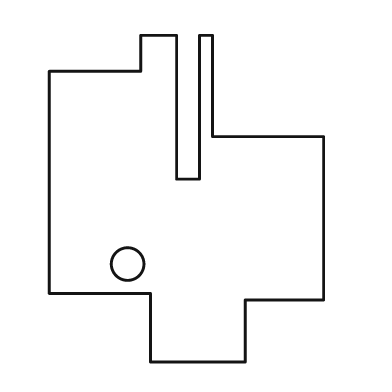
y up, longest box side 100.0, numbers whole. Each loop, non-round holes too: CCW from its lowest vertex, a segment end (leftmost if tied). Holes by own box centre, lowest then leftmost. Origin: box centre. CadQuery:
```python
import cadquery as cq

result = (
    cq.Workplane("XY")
    .moveTo(-11.0, -50.0)
    .lineTo(18.0, -50.0)
    .lineTo(18.0, -31.0)
    .lineTo(42.0, -31.0)
    .lineTo(42.0, 19.0)
    .lineTo(8.0, 19.0)
    .lineTo(8.0, 50.0)
    .lineTo(4.0, 50.0)
    .lineTo(4.0, 6.0)
    .lineTo(-3.0, 6.0)
    .lineTo(-3.0, 50.0)
    .lineTo(-14.0, 50.0)
    .lineTo(-14.0, 39.0)
    .lineTo(-42.0, 39.0)
    .lineTo(-42.0, -29.0)
    .lineTo(-11.0, -29.0)
    .close()
    .moveTo(-18.0, -20.0)
    .circle(5.0)
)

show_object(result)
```